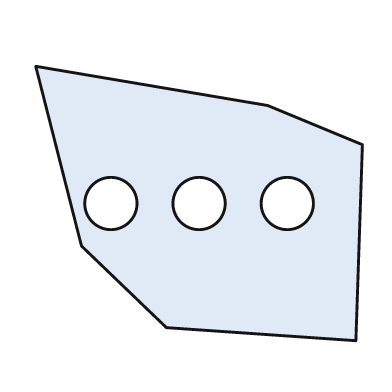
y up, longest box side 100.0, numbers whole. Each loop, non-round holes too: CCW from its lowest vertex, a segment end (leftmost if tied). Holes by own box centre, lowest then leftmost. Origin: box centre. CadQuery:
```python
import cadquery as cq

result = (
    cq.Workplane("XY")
    .moveTo(48.0, -42.0)
    .lineTo(50.0, 18.0)
    .lineTo(21.0, 30.0)
    .lineTo(-50.0, 42.0)
    .lineTo(-36.0, -13.0)
    .lineTo(-10.0, -38.0)
    .close()
    .moveTo(-27.0, 0.0)
    .circle(8.0)
    .moveTo(0.0, 0.0)
    .circle(8.0)
    .moveTo(27.0, 0.0)
    .circle(8.0)
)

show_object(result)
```